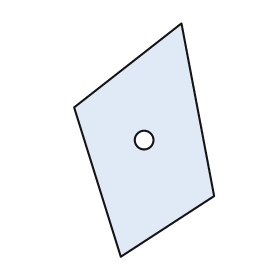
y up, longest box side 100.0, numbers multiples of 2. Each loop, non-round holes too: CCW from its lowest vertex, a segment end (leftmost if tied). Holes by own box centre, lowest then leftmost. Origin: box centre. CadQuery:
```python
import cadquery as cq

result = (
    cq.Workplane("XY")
    .moveTo(-10.0, -50.0)
    .lineTo(30.0, -24.0)
    .lineTo(16.0, 50.0)
    .lineTo(-30.0, 14.0)
    .close()
    .moveTo(0.0, 0.0)
    .circle(4.0)
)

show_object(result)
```